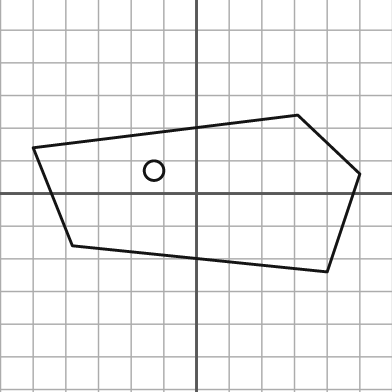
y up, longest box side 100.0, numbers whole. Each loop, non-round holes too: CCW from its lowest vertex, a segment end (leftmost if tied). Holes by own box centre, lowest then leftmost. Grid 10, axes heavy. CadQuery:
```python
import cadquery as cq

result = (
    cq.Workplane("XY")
    .moveTo(40.0, -24.0)
    .lineTo(50.0, 6.0)
    .lineTo(31.0, 24.0)
    .lineTo(-50.0, 14.0)
    .lineTo(-38.0, -16.0)
    .close()
    .moveTo(-13.0, 7.0)
    .circle(3.0)
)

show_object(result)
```